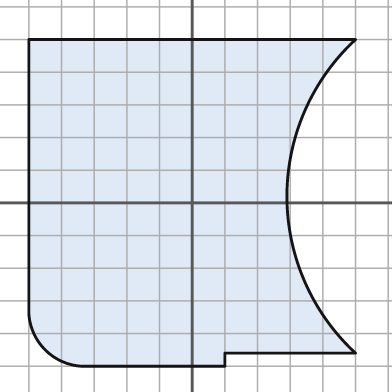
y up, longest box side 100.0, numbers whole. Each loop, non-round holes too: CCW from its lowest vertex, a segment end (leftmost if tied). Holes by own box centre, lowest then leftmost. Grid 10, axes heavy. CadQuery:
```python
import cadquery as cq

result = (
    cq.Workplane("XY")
    .moveTo(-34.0, -50.0)
    .lineTo(10.0, -50.0)
    .lineTo(10.0, -46.0)
    .lineTo(50.0, -46.0)
    .threePointArc((29.0, 2.0), (50.0, 50.0))
    .lineTo(-50.0, 50.0)
    .lineTo(-50.0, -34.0)
    .threePointArc((-45.0, -45.0), (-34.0, -50.0))
    .close()
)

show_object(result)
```